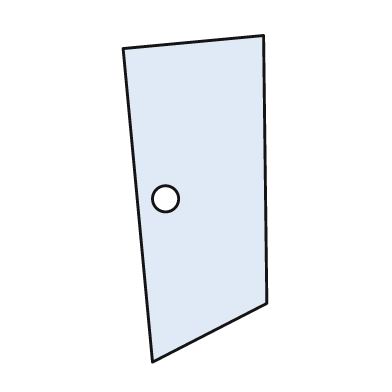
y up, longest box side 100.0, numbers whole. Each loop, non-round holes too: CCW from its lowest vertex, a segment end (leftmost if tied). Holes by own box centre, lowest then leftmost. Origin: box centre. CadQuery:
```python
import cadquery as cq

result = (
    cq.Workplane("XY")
    .moveTo(-13.0, -50.0)
    .lineTo(22.0, -32.0)
    .lineTo(21.0, 50.0)
    .lineTo(-22.0, 46.0)
    .close()
    .moveTo(-9.0, 0.0)
    .circle(4.0)
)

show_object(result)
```